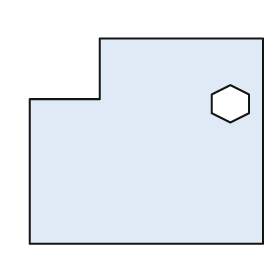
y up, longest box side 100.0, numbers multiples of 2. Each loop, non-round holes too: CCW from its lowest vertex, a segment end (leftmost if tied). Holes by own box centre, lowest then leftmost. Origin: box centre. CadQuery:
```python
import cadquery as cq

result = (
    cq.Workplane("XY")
    .moveTo(-50.0, -44.0)
    .lineTo(50.0, -44.0)
    .lineTo(50.0, 44.0)
    .lineTo(-20.0, 44.0)
    .lineTo(-20.0, 18.0)
    .lineTo(-50.0, 18.0)
    .close()
    .moveTo(36.0, 8.0)
    .lineTo(44.0, 12.0)
    .lineTo(44.0, 20.0)
    .lineTo(36.0, 24.0)
    .lineTo(28.0, 20.0)
    .lineTo(28.0, 12.0)
    .close()
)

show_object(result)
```